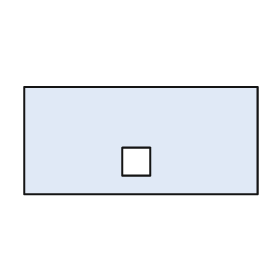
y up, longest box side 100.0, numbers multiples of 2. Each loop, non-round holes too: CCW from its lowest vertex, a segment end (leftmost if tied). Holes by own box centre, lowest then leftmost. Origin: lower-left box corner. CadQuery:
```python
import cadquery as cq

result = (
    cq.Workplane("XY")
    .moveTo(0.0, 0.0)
    .lineTo(100.0, 0.0)
    .lineTo(100.0, 46.0)
    .lineTo(0.0, 46.0)
    .close()
    .moveTo(42.0, 8.0)
    .lineTo(54.0, 8.0)
    .lineTo(54.0, 20.0)
    .lineTo(42.0, 20.0)
    .close()
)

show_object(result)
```